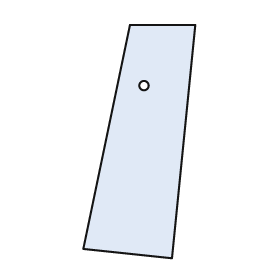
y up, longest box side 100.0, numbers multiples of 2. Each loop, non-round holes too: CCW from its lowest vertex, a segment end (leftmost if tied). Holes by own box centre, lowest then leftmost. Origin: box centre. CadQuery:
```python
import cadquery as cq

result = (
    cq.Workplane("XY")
    .moveTo(14.0, -50.0)
    .lineTo(24.0, 50.0)
    .lineTo(-4.0, 50.0)
    .lineTo(-24.0, -46.0)
    .close()
    .moveTo(2.0, 24.0)
    .circle(2.0)
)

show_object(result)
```